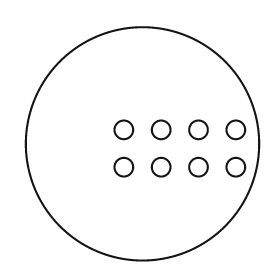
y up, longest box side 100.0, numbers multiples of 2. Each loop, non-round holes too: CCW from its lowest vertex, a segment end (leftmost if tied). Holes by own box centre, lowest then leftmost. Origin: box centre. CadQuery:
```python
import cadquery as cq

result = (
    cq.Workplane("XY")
    .moveTo(0.0, 0.0)
    .circle(50.0)
    .moveTo(-8.0, -10.0)
    .circle(4.0)
    .moveTo(8.0, -10.0)
    .circle(4.0)
    .moveTo(24.0, -10.0)
    .circle(4.0)
    .moveTo(40.0, -10.0)
    .circle(4.0)
    .moveTo(-8.0, 6.0)
    .circle(4.0)
    .moveTo(8.0, 6.0)
    .circle(4.0)
    .moveTo(24.0, 6.0)
    .circle(4.0)
    .moveTo(40.0, 6.0)
    .circle(4.0)
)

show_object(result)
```